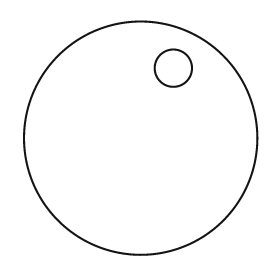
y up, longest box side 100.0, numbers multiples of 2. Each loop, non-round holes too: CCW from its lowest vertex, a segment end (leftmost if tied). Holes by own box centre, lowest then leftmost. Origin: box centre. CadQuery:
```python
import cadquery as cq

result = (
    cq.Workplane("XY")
    .moveTo(0.0, 0.0)
    .circle(50.0)
    .moveTo(14.0, 30.0)
    .circle(8.0)
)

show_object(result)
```